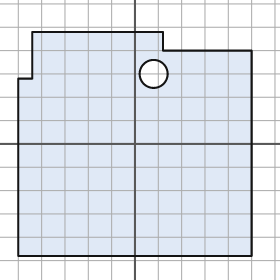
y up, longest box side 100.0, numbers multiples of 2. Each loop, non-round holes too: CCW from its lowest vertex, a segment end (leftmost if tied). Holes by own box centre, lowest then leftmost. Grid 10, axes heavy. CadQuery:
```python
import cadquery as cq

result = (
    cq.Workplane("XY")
    .moveTo(-50.0, -48.0)
    .lineTo(50.0, -48.0)
    .lineTo(50.0, 40.0)
    .lineTo(12.0, 40.0)
    .lineTo(12.0, 48.0)
    .lineTo(-44.0, 48.0)
    .lineTo(-44.0, 28.0)
    .lineTo(-50.0, 28.0)
    .close()
    .moveTo(8.0, 30.0)
    .circle(6.0)
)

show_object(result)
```